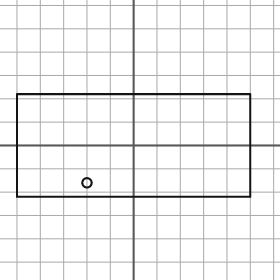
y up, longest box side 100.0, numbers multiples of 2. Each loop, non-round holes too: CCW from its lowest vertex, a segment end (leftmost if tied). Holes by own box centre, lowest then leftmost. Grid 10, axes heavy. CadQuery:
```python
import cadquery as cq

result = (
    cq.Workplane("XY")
    .moveTo(-50.0, -22.0)
    .lineTo(50.0, -22.0)
    .lineTo(50.0, 22.0)
    .lineTo(-50.0, 22.0)
    .close()
    .moveTo(-20.0, -16.0)
    .circle(2.0)
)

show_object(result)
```